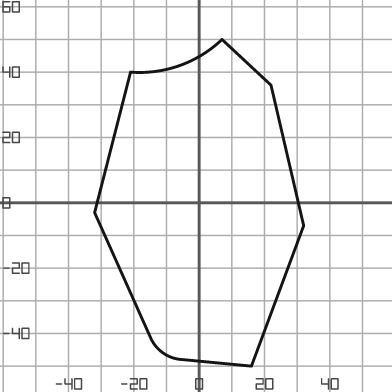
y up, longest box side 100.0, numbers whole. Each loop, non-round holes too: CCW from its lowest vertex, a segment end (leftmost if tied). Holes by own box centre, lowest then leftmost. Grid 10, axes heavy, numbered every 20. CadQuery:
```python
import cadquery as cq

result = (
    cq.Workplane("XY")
    .moveTo(16.0, -50.0)
    .lineTo(32.0, -7.0)
    .lineTo(22.0, 36.0)
    .lineTo(7.0, 50.0)
    .threePointArc((-6.0, 42.0), (-21.0, 40.0))
    .lineTo(-32.0, -3.0)
    .lineTo(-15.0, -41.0)
    .threePointArc((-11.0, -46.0), (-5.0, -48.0))
    .close()
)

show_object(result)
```